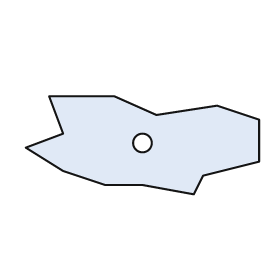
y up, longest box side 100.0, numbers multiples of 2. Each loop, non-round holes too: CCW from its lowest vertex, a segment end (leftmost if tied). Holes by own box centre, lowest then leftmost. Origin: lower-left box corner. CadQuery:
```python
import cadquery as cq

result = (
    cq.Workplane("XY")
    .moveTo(72.0, 0.0)
    .lineTo(76.0, 8.0)
    .lineTo(100.0, 14.0)
    .lineTo(100.0, 32.0)
    .lineTo(82.0, 38.0)
    .lineTo(56.0, 34.0)
    .lineTo(38.0, 42.0)
    .lineTo(10.0, 42.0)
    .lineTo(16.0, 26.0)
    .lineTo(0.0, 20.0)
    .lineTo(16.0, 10.0)
    .lineTo(34.0, 4.0)
    .lineTo(50.0, 4.0)
    .close()
    .moveTo(50.0, 22.0)
    .circle(4.0)
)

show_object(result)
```